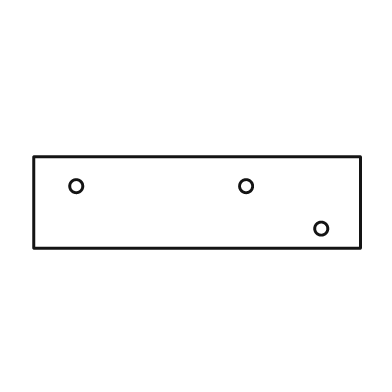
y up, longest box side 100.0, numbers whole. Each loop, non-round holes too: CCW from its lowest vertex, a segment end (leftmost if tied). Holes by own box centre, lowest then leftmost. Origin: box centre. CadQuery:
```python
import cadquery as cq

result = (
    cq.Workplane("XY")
    .moveTo(-50.0, -14.0)
    .lineTo(50.0, -14.0)
    .lineTo(50.0, 14.0)
    .lineTo(-50.0, 14.0)
    .close()
    .moveTo(38.0, -8.0)
    .circle(2.0)
    .moveTo(-37.0, 5.0)
    .circle(2.0)
    .moveTo(15.0, 5.0)
    .circle(2.0)
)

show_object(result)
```